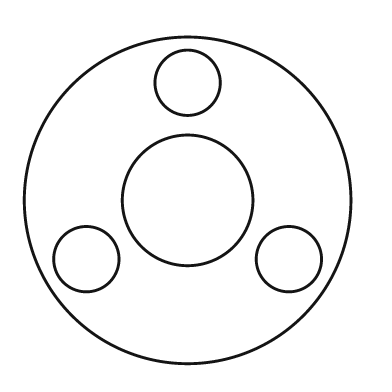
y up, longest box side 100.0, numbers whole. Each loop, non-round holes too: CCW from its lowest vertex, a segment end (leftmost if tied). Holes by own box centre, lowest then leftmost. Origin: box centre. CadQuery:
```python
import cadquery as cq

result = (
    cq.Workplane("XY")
    .moveTo(0.0, 0.0)
    .circle(50.0)
    .moveTo(-31.0, -18.0)
    .circle(10.0)
    .moveTo(31.0, -18.0)
    .circle(10.0)
    .moveTo(0.0, 0.0)
    .circle(20.0)
    .moveTo(0.0, 36.0)
    .circle(10.0)
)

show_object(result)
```